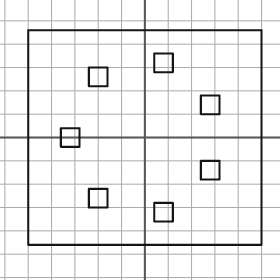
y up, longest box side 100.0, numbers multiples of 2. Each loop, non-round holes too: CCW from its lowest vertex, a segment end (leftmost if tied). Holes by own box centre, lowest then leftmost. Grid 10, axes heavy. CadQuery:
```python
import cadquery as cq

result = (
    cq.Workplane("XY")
    .moveTo(-50.0, -46.0)
    .lineTo(50.0, -46.0)
    .lineTo(50.0, 46.0)
    .lineTo(-50.0, 46.0)
    .close()
    .moveTo(4.0, -36.0)
    .lineTo(12.0, -36.0)
    .lineTo(12.0, -28.0)
    .lineTo(4.0, -28.0)
    .close()
    .moveTo(-24.0, -30.0)
    .lineTo(-16.0, -30.0)
    .lineTo(-16.0, -22.0)
    .lineTo(-24.0, -22.0)
    .close()
    .moveTo(24.0, -18.0)
    .lineTo(32.0, -18.0)
    .lineTo(32.0, -10.0)
    .lineTo(24.0, -10.0)
    .close()
    .moveTo(-36.0, -4.0)
    .lineTo(-28.0, -4.0)
    .lineTo(-28.0, 4.0)
    .lineTo(-36.0, 4.0)
    .close()
    .moveTo(24.0, 10.0)
    .lineTo(32.0, 10.0)
    .lineTo(32.0, 18.0)
    .lineTo(24.0, 18.0)
    .close()
    .moveTo(-24.0, 22.0)
    .lineTo(-16.0, 22.0)
    .lineTo(-16.0, 30.0)
    .lineTo(-24.0, 30.0)
    .close()
    .moveTo(4.0, 28.0)
    .lineTo(12.0, 28.0)
    .lineTo(12.0, 36.0)
    .lineTo(4.0, 36.0)
    .close()
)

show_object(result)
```